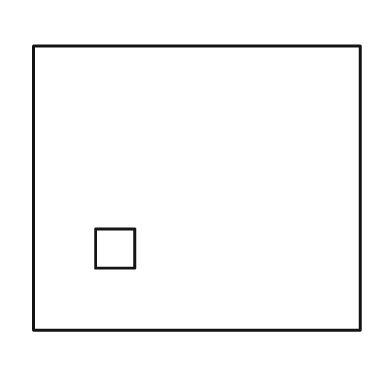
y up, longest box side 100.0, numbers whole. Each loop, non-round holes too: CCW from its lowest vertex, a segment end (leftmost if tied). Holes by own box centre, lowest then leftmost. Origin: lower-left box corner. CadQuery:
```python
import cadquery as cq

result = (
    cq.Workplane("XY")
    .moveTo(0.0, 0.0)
    .lineTo(100.0, 0.0)
    .lineTo(100.0, 87.0)
    .lineTo(0.0, 87.0)
    .close()
    .moveTo(19.0, 19.0)
    .lineTo(31.0, 19.0)
    .lineTo(31.0, 31.0)
    .lineTo(19.0, 31.0)
    .close()
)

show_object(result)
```